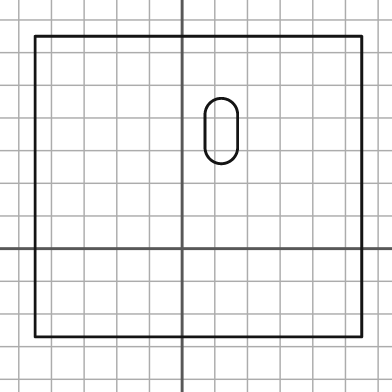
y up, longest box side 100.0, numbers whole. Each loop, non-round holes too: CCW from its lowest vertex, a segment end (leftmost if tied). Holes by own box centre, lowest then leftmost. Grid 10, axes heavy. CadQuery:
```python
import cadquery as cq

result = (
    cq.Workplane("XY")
    .moveTo(-45.0, -27.0)
    .lineTo(55.0, -27.0)
    .lineTo(55.0, 65.0)
    .lineTo(-45.0, 65.0)
    .close()
    .moveTo(7.0, 31.0)
    .threePointArc((12.0, 26.0), (17.0, 31.0))
    .lineTo(17.0, 41.0)
    .threePointArc((12.0, 46.0), (7.0, 41.0))
    .close()
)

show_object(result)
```